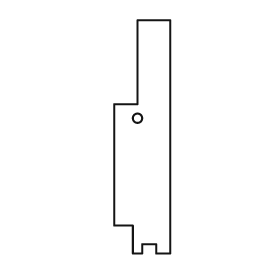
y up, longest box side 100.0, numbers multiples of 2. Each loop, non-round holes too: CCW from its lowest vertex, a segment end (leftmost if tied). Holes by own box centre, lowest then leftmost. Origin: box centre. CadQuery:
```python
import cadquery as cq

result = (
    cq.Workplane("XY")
    .moveTo(-4.0, -50.0)
    .lineTo(0.0, -50.0)
    .lineTo(0.0, -46.0)
    .lineTo(6.0, -46.0)
    .lineTo(6.0, -50.0)
    .lineTo(12.0, -50.0)
    .lineTo(12.0, 50.0)
    .lineTo(-2.0, 50.0)
    .lineTo(-2.0, 14.0)
    .lineTo(-12.0, 14.0)
    .lineTo(-12.0, -38.0)
    .lineTo(-4.0, -38.0)
    .close()
    .moveTo(-2.0, 8.0)
    .circle(2.0)
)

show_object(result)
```